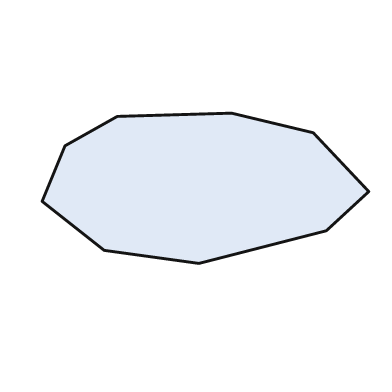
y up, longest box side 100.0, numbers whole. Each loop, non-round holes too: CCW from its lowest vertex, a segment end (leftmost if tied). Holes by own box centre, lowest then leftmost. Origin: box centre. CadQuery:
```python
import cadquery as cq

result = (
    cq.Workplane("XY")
    .moveTo(-2.0, -23.0)
    .lineTo(37.0, -13.0)
    .lineTo(50.0, -1.0)
    .lineTo(33.0, 17.0)
    .lineTo(8.0, 23.0)
    .lineTo(-27.0, 22.0)
    .lineTo(-43.0, 13.0)
    .lineTo(-50.0, -4.0)
    .lineTo(-31.0, -19.0)
    .close()
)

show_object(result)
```